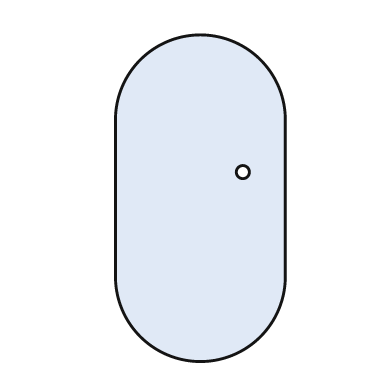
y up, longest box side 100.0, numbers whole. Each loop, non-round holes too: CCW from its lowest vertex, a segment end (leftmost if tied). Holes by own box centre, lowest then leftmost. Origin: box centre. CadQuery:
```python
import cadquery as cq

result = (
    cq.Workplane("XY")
    .moveTo(-26.0, -24.0)
    .threePointArc((0.0, -50.0), (26.0, -24.0))
    .lineTo(26.0, 24.0)
    .threePointArc((0.0, 50.0), (-26.0, 24.0))
    .close()
    .moveTo(13.0, 8.0)
    .circle(2.0)
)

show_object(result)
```